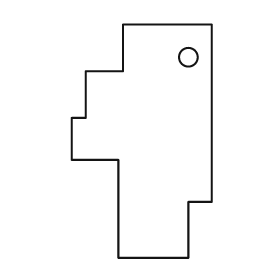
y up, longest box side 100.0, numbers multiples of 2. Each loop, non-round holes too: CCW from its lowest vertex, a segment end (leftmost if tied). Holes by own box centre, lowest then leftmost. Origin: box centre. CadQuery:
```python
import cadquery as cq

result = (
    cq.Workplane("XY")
    .moveTo(-10.0, -50.0)
    .lineTo(20.0, -50.0)
    .lineTo(20.0, -26.0)
    .lineTo(30.0, -26.0)
    .lineTo(30.0, 50.0)
    .lineTo(-8.0, 50.0)
    .lineTo(-8.0, 30.0)
    .lineTo(-24.0, 30.0)
    .lineTo(-24.0, 10.0)
    .lineTo(-30.0, 10.0)
    .lineTo(-30.0, -8.0)
    .lineTo(-10.0, -8.0)
    .close()
    .moveTo(20.0, 36.0)
    .circle(4.0)
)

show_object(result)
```